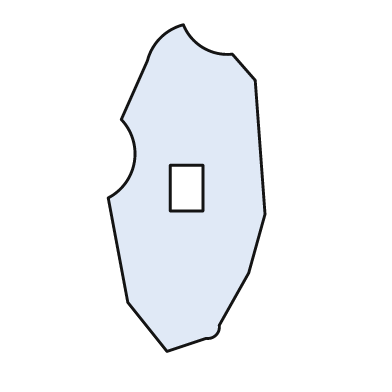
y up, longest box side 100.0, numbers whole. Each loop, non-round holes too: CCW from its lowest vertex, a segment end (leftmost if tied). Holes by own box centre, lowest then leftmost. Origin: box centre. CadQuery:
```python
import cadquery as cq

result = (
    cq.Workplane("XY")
    .moveTo(-6.0, -50.0)
    .lineTo(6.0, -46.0)
    .threePointArc((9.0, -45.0), (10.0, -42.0))
    .lineTo(19.0, -26.0)
    .lineTo(24.0, -8.0)
    .lineTo(21.0, 33.0)
    .lineTo(14.0, 41.0)
    .threePointArc((5.0, 43.0), (-1.0, 50.0))
    .threePointArc((-8.0, 46.0), (-12.0, 39.0))
    .lineTo(-20.0, 21.0)
    .threePointArc((-16.0, 8.0), (-24.0, -3.0))
    .lineTo(-18.0, -35.0)
    .close()
    .moveTo(-5.0, -7.0)
    .lineTo(5.0, -7.0)
    .lineTo(5.0, 7.0)
    .lineTo(-5.0, 7.0)
    .close()
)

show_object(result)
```